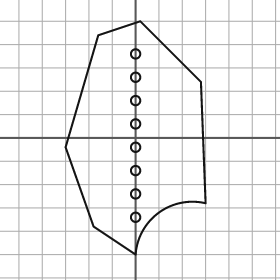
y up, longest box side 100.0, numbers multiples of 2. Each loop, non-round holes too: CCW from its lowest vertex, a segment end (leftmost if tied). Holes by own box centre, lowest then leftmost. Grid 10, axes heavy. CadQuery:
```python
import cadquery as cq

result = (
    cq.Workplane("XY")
    .moveTo(0.0, -50.0)
    .threePointArc((10.0, -32.0), (30.0, -28.0))
    .lineTo(28.0, 24.0)
    .lineTo(2.0, 50.0)
    .lineTo(-16.0, 44.0)
    .lineTo(-30.0, -4.0)
    .lineTo(-18.0, -38.0)
    .close()
    .moveTo(0.0, -34.0)
    .circle(2.0)
    .moveTo(0.0, -24.0)
    .circle(2.0)
    .moveTo(0.0, -14.0)
    .circle(2.0)
    .moveTo(0.0, -4.0)
    .circle(2.0)
    .moveTo(0.0, 6.0)
    .circle(2.0)
    .moveTo(0.0, 16.0)
    .circle(2.0)
    .moveTo(0.0, 26.0)
    .circle(2.0)
    .moveTo(0.0, 36.0)
    .circle(2.0)
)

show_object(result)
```